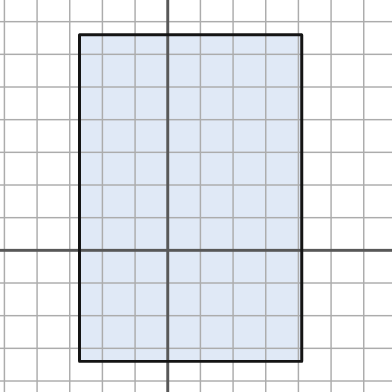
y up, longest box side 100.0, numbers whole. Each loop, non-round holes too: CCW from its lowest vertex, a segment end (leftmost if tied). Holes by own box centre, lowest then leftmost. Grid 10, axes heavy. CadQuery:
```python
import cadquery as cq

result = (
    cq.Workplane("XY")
    .moveTo(-27.0, -34.0)
    .lineTo(41.0, -34.0)
    .lineTo(41.0, 66.0)
    .lineTo(-27.0, 66.0)
    .close()
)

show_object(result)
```